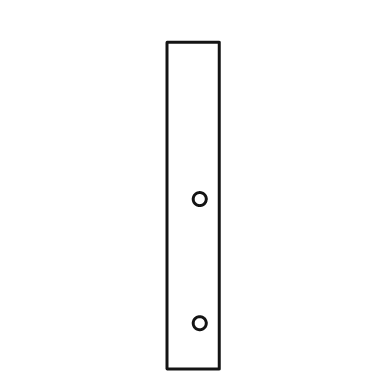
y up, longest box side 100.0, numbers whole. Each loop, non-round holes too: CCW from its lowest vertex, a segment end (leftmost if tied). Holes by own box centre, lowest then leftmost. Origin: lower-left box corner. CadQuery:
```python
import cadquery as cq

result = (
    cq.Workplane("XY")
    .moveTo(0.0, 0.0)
    .lineTo(16.0, 0.0)
    .lineTo(16.0, 100.0)
    .lineTo(0.0, 100.0)
    .close()
    .moveTo(10.0, 14.0)
    .circle(2.0)
    .moveTo(10.0, 52.0)
    .circle(2.0)
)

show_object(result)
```